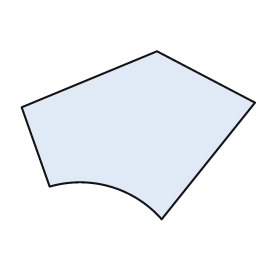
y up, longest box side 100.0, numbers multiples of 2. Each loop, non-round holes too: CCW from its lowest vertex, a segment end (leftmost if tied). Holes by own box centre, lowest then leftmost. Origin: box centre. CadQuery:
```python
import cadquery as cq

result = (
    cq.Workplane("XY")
    .moveTo(10.0, -36.0)
    .lineTo(50.0, 14.0)
    .lineTo(8.0, 36.0)
    .lineTo(-50.0, 12.0)
    .lineTo(-38.0, -22.0)
    .threePointArc((-12.0, -22.0), (10.0, -36.0))
    .close()
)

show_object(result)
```